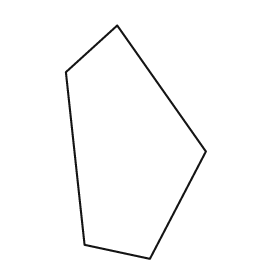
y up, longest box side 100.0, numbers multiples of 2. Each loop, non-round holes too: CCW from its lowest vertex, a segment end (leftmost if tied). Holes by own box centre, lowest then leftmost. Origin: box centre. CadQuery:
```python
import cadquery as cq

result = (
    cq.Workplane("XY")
    .moveTo(6.0, -50.0)
    .lineTo(30.0, -4.0)
    .lineTo(-8.0, 50.0)
    .lineTo(-30.0, 30.0)
    .lineTo(-22.0, -44.0)
    .close()
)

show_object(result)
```